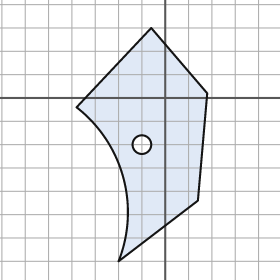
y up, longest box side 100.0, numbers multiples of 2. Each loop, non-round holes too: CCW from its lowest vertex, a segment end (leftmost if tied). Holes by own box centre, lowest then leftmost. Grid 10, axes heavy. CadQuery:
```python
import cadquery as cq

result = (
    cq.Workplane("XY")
    .moveTo(-20.0, -70.0)
    .lineTo(14.0, -44.0)
    .lineTo(18.0, 2.0)
    .lineTo(-6.0, 30.0)
    .lineTo(-38.0, -4.0)
    .threePointArc((-18.0, -34.0), (-20.0, -70.0))
    .close()
    .moveTo(-10.0, -20.0)
    .circle(4.0)
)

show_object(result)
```